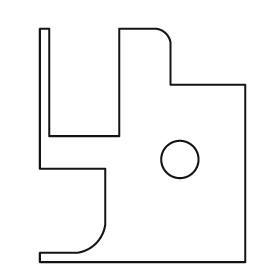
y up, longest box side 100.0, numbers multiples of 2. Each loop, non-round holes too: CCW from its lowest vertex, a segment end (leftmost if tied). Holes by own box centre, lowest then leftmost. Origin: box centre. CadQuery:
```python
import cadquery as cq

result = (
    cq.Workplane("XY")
    .moveTo(-44.0, -50.0)
    .lineTo(44.0, -50.0)
    .lineTo(44.0, 26.0)
    .lineTo(12.0, 26.0)
    .lineTo(12.0, 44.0)
    .threePointArc((10.0, 48.0), (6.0, 50.0))
    .lineTo(-10.0, 50.0)
    .lineTo(-10.0, 4.0)
    .lineTo(-40.0, 4.0)
    .lineTo(-40.0, 50.0)
    .lineTo(-44.0, 50.0)
    .lineTo(-44.0, -10.0)
    .lineTo(-16.0, -10.0)
    .lineTo(-16.0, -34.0)
    .threePointArc((-20.0, -42.0), (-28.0, -46.0))
    .lineTo(-44.0, -46.0)
    .close()
    .moveTo(16.0, -6.0)
    .circle(8.0)
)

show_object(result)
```